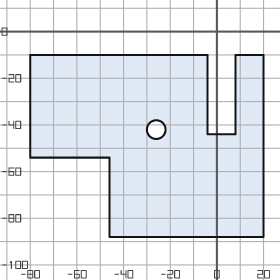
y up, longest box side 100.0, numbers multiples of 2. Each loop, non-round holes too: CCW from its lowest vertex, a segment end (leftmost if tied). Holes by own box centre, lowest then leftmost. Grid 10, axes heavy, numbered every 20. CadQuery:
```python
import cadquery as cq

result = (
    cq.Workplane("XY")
    .moveTo(-46.0, -88.0)
    .lineTo(20.0, -88.0)
    .lineTo(20.0, -10.0)
    .lineTo(8.0, -10.0)
    .lineTo(8.0, -44.0)
    .lineTo(-4.0, -44.0)
    .lineTo(-4.0, -10.0)
    .lineTo(-80.0, -10.0)
    .lineTo(-80.0, -54.0)
    .lineTo(-46.0, -54.0)
    .close()
    .moveTo(-26.0, -42.0)
    .circle(4.0)
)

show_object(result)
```